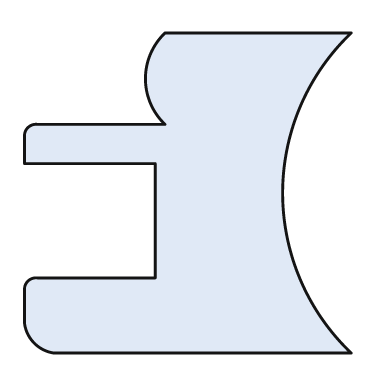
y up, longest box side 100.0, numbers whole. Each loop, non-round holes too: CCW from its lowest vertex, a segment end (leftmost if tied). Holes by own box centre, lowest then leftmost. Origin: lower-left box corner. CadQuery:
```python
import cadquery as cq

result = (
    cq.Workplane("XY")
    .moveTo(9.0, 0.0)
    .lineTo(100.0, 0.0)
    .threePointArc((79.0, 49.0), (100.0, 98.0))
    .lineTo(43.0, 98.0)
    .threePointArc((37.0, 84.0), (43.0, 70.0))
    .lineTo(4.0, 70.0)
    .threePointArc((1.0, 69.0), (0.0, 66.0))
    .lineTo(0.0, 58.0)
    .lineTo(40.0, 58.0)
    .lineTo(40.0, 23.0)
    .lineTo(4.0, 23.0)
    .threePointArc((1.0, 22.0), (0.0, 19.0))
    .lineTo(0.0, 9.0)
    .threePointArc((3.0, 3.0), (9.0, 0.0))
    .close()
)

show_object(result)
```